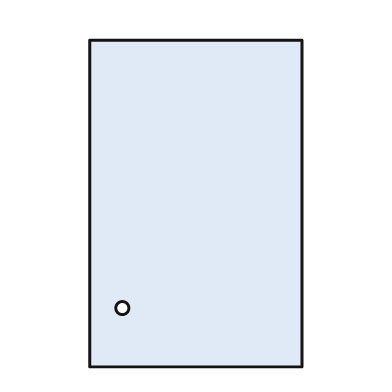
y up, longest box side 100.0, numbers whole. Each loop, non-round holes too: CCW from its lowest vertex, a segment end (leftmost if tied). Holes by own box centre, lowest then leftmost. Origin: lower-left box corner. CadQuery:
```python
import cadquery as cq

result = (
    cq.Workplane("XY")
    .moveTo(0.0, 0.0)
    .lineTo(65.0, 0.0)
    .lineTo(65.0, 100.0)
    .lineTo(0.0, 100.0)
    .close()
    .moveTo(10.0, 18.0)
    .circle(2.0)
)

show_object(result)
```